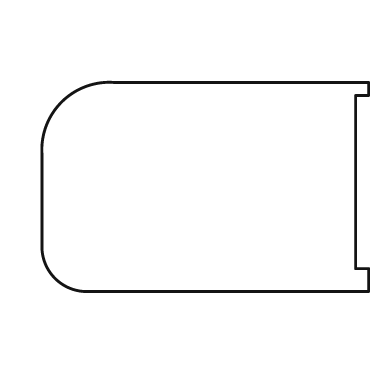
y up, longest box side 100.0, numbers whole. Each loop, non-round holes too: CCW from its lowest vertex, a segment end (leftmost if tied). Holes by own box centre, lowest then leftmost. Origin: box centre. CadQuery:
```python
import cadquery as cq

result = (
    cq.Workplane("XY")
    .moveTo(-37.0, -32.0)
    .lineTo(50.0, -32.0)
    .lineTo(50.0, -25.0)
    .lineTo(46.0, -25.0)
    .lineTo(46.0, 28.0)
    .lineTo(50.0, 28.0)
    .lineTo(50.0, 32.0)
    .lineTo(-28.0, 32.0)
    .threePointArc((-44.0, 26.0), (-50.0, 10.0))
    .lineTo(-50.0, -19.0)
    .threePointArc((-46.0, -28.0), (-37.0, -32.0))
    .close()
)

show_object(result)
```